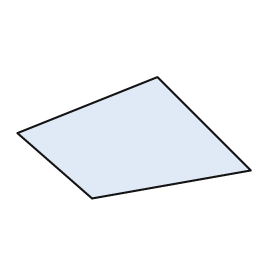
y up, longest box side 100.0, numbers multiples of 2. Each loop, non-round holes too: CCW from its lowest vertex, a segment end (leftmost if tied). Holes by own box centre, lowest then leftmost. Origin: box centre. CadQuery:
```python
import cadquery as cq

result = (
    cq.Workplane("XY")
    .moveTo(-18.0, -26.0)
    .lineTo(50.0, -14.0)
    .lineTo(10.0, 26.0)
    .lineTo(-50.0, 2.0)
    .close()
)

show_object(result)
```